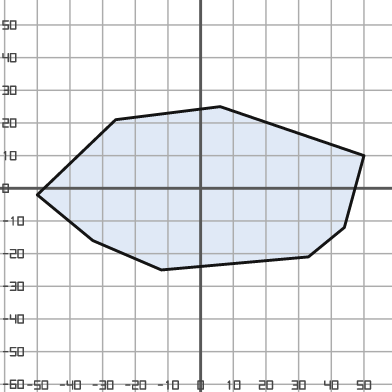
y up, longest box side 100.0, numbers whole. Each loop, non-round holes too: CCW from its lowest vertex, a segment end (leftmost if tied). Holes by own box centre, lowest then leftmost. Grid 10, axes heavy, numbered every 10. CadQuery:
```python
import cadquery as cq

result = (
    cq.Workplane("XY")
    .moveTo(-12.0, -25.0)
    .lineTo(33.0, -21.0)
    .lineTo(44.0, -12.0)
    .lineTo(50.0, 10.0)
    .lineTo(6.0, 25.0)
    .lineTo(-26.0, 21.0)
    .lineTo(-50.0, -2.0)
    .lineTo(-33.0, -16.0)
    .close()
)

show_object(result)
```